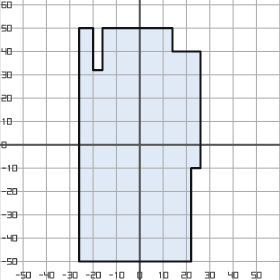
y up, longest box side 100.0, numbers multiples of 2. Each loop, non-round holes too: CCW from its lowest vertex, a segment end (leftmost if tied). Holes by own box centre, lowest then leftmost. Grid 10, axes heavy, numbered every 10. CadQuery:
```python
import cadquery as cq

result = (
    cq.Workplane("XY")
    .moveTo(-26.0, -50.0)
    .lineTo(22.0, -50.0)
    .lineTo(22.0, -10.0)
    .lineTo(26.0, -10.0)
    .lineTo(26.0, 40.0)
    .lineTo(14.0, 40.0)
    .lineTo(14.0, 50.0)
    .lineTo(-16.0, 50.0)
    .lineTo(-16.0, 32.0)
    .lineTo(-20.0, 32.0)
    .lineTo(-20.0, 50.0)
    .lineTo(-26.0, 50.0)
    .close()
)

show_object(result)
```